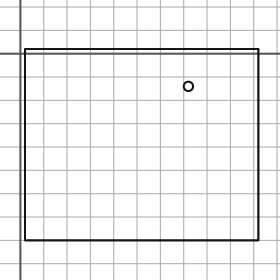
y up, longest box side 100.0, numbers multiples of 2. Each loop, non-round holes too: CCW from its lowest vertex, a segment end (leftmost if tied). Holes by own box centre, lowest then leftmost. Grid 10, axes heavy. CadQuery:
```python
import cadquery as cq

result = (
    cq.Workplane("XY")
    .moveTo(2.0, -80.0)
    .lineTo(102.0, -80.0)
    .lineTo(102.0, 2.0)
    .lineTo(2.0, 2.0)
    .close()
    .moveTo(72.0, -14.0)
    .circle(2.0)
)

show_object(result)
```